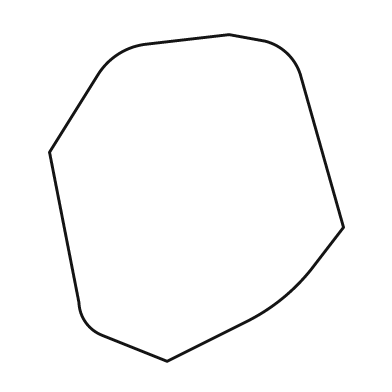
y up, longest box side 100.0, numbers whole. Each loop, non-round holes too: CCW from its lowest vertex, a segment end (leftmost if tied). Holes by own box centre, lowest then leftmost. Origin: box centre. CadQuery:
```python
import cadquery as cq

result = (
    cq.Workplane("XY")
    .moveTo(-9.0, -50.0)
    .lineTo(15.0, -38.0)
    .threePointArc((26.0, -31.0), (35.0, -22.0))
    .lineTo(45.0, -9.0)
    .lineTo(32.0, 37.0)
    .threePointArc((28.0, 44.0), (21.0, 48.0))
    .lineTo(10.0, 50.0)
    .lineTo(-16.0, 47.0)
    .threePointArc((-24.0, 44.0), (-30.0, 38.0))
    .lineTo(-45.0, 14.0)
    .lineTo(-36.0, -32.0)
    .threePointArc((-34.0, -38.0), (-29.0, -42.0))
    .close()
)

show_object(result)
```